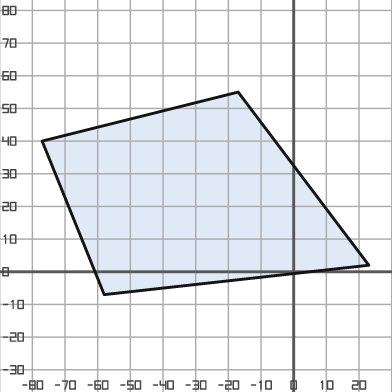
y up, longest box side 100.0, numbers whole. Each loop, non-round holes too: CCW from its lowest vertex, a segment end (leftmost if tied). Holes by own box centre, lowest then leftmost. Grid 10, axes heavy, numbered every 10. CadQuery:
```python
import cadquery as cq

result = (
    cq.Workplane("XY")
    .moveTo(-58.0, -7.0)
    .lineTo(23.0, 2.0)
    .lineTo(-17.0, 55.0)
    .lineTo(-77.0, 40.0)
    .close()
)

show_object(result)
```